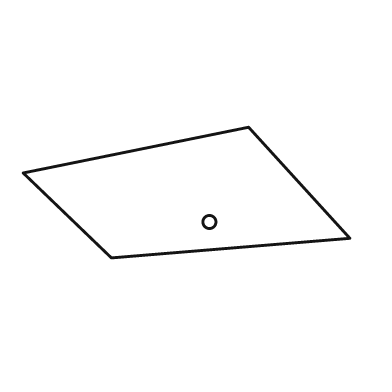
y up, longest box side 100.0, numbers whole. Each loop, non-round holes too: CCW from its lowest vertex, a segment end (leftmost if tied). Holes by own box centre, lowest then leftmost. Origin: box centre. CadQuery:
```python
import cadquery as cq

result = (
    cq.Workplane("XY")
    .moveTo(-23.0, -20.0)
    .lineTo(50.0, -14.0)
    .lineTo(19.0, 20.0)
    .lineTo(-50.0, 6.0)
    .close()
    .moveTo(7.0, -9.0)
    .circle(2.0)
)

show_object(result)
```